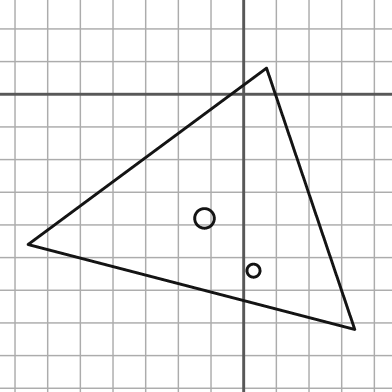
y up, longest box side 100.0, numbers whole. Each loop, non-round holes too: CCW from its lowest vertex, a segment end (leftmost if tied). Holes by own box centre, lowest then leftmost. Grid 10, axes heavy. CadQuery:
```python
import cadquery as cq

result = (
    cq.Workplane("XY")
    .moveTo(34.0, -72.0)
    .lineTo(7.0, 8.0)
    .lineTo(-66.0, -46.0)
    .close()
    .moveTo(3.0, -54.0)
    .circle(2.0)
    .moveTo(-12.0, -38.0)
    .circle(3.0)
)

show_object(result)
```